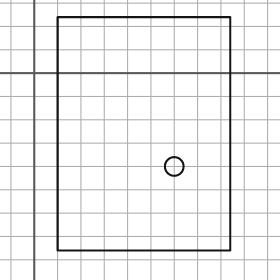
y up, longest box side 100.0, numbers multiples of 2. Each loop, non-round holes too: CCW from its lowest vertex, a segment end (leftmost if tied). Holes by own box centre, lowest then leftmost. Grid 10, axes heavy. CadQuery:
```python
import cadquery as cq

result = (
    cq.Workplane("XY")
    .moveTo(10.0, -76.0)
    .lineTo(84.0, -76.0)
    .lineTo(84.0, 24.0)
    .lineTo(10.0, 24.0)
    .close()
    .moveTo(60.0, -40.0)
    .circle(4.0)
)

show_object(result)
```